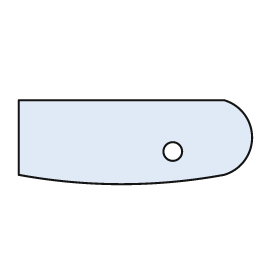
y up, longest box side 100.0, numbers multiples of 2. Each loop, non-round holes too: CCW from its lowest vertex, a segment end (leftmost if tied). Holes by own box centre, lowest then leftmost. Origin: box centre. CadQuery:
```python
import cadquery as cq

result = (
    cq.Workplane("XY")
    .moveTo(-50.0, -14.0)
    .threePointArc((-6.0, -18.0), (38.0, -14.0))
    .threePointArc((50.0, 2.0), (38.0, 18.0))
    .lineTo(-50.0, 18.0)
    .close()
    .moveTo(16.0, -4.0)
    .circle(4.0)
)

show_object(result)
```